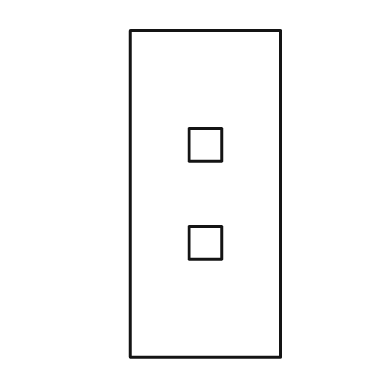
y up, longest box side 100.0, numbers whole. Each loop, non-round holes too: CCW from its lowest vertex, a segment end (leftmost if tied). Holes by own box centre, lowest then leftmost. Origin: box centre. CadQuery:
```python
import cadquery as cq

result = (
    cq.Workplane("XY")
    .moveTo(-23.0, -50.0)
    .lineTo(23.0, -50.0)
    .lineTo(23.0, 50.0)
    .lineTo(-23.0, 50.0)
    .close()
    .moveTo(-5.0, -20.0)
    .lineTo(5.0, -20.0)
    .lineTo(5.0, -10.0)
    .lineTo(-5.0, -10.0)
    .close()
    .moveTo(-5.0, 10.0)
    .lineTo(5.0, 10.0)
    .lineTo(5.0, 20.0)
    .lineTo(-5.0, 20.0)
    .close()
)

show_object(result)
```